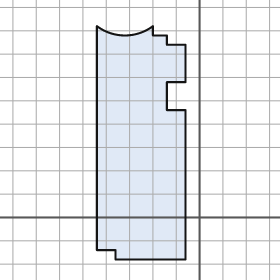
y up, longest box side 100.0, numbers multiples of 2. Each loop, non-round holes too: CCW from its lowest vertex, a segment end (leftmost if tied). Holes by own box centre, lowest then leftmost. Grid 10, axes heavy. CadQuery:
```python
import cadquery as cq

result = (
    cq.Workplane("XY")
    .moveTo(-36.0, -18.0)
    .lineTo(-6.0, -18.0)
    .lineTo(-6.0, 46.0)
    .lineTo(-14.0, 46.0)
    .lineTo(-14.0, 58.0)
    .lineTo(-6.0, 58.0)
    .lineTo(-6.0, 74.0)
    .lineTo(-14.0, 74.0)
    .lineTo(-14.0, 78.0)
    .lineTo(-20.0, 78.0)
    .lineTo(-20.0, 82.0)
    .threePointArc((-32.0, 78.0), (-44.0, 82.0))
    .lineTo(-44.0, -14.0)
    .lineTo(-36.0, -14.0)
    .close()
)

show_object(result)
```